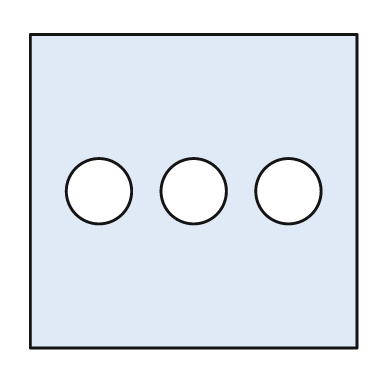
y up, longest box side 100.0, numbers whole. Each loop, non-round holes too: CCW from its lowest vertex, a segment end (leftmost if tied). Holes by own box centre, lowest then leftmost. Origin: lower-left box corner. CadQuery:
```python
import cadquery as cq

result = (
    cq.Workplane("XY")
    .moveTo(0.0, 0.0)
    .lineTo(100.0, 0.0)
    .lineTo(100.0, 96.0)
    .lineTo(0.0, 96.0)
    .close()
    .moveTo(21.0, 48.0)
    .circle(10.0)
    .moveTo(50.0, 48.0)
    .circle(10.0)
    .moveTo(79.0, 48.0)
    .circle(10.0)
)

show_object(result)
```